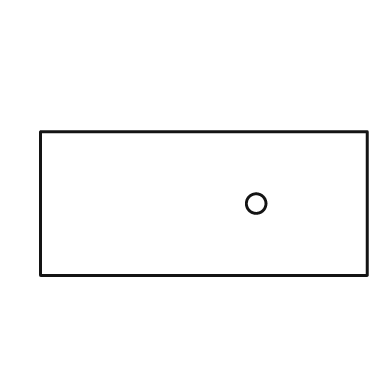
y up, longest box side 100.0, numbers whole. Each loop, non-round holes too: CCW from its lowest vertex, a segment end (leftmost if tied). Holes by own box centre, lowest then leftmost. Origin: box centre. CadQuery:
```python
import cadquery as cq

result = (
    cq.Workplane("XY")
    .moveTo(-50.0, -22.0)
    .lineTo(50.0, -22.0)
    .lineTo(50.0, 22.0)
    .lineTo(-50.0, 22.0)
    .close()
    .moveTo(16.0, 0.0)
    .circle(3.0)
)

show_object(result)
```